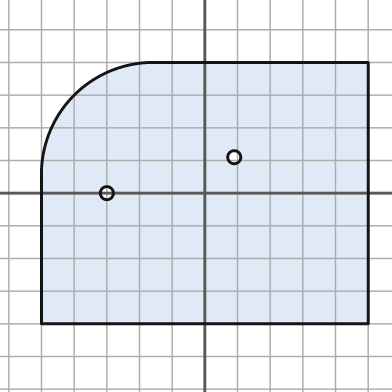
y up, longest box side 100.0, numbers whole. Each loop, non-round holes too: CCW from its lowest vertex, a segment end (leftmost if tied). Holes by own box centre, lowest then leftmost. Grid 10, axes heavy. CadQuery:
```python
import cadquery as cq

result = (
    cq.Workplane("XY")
    .moveTo(-50.0, -40.0)
    .lineTo(50.0, -40.0)
    .lineTo(50.0, 40.0)
    .lineTo(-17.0, 40.0)
    .threePointArc((-40.0, 30.0), (-50.0, 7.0))
    .close()
    .moveTo(-30.0, 0.0)
    .circle(2.0)
    .moveTo(9.0, 11.0)
    .circle(2.0)
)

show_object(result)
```